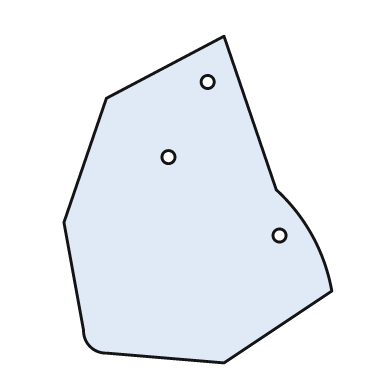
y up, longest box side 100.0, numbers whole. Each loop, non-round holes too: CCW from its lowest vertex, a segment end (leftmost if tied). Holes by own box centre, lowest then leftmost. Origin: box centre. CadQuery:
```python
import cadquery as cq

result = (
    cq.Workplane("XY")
    .moveTo(8.0, -50.0)
    .lineTo(41.0, -28.0)
    .threePointArc((35.0, -11.0), (24.0, 3.0))
    .lineTo(8.0, 50.0)
    .lineTo(-28.0, 31.0)
    .lineTo(-41.0, -7.0)
    .lineTo(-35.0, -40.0)
    .threePointArc((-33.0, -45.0), (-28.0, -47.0))
    .close()
    .moveTo(25.0, -11.0)
    .circle(2.0)
    .moveTo(-9.0, 13.0)
    .circle(2.0)
    .moveTo(3.0, 36.0)
    .circle(2.0)
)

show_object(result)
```